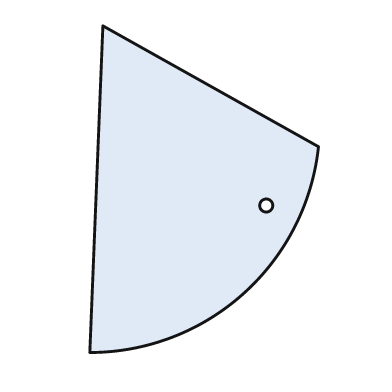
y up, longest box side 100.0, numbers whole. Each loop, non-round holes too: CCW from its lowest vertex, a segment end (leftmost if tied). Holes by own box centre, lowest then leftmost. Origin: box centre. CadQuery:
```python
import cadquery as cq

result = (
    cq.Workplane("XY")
    .moveTo(-35.0, -50.0)
    .threePointArc((12.0, -32.0), (35.0, 13.0))
    .lineTo(-31.0, 50.0)
    .close()
    .moveTo(19.0, -5.0)
    .circle(2.0)
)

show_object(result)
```